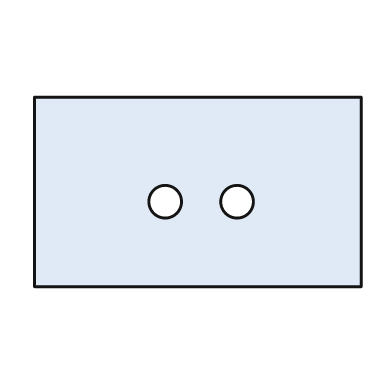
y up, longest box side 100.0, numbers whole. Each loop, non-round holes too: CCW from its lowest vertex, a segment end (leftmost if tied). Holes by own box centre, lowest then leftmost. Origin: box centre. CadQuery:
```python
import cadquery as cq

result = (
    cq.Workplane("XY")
    .moveTo(-50.0, -29.0)
    .lineTo(50.0, -29.0)
    .lineTo(50.0, 29.0)
    .lineTo(-50.0, 29.0)
    .close()
    .moveTo(-10.0, -3.0)
    .circle(5.0)
    .moveTo(12.0, -3.0)
    .circle(5.0)
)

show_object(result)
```